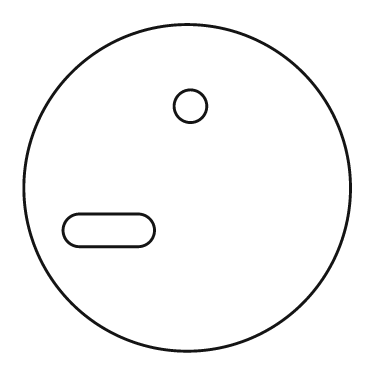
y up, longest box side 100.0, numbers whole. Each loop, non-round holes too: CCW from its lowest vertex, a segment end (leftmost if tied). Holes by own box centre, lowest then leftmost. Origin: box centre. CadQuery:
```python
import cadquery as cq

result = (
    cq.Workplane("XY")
    .moveTo(0.0, 0.0)
    .circle(50.0)
    .moveTo(-33.0, -18.0)
    .lineTo(-15.0, -18.0)
    .threePointArc((-10.0, -13.0), (-15.0, -8.0))
    .lineTo(-33.0, -8.0)
    .threePointArc((-38.0, -13.0), (-33.0, -18.0))
    .close()
    .moveTo(1.0, 25.0)
    .circle(5.0)
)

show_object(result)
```